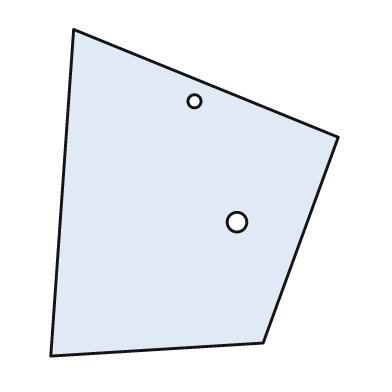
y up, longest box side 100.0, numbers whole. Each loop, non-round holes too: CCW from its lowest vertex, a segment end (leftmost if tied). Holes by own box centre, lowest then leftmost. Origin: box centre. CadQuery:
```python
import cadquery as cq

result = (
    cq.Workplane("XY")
    .moveTo(-44.0, -50.0)
    .lineTo(21.0, -46.0)
    .lineTo(44.0, 17.0)
    .lineTo(-37.0, 50.0)
    .close()
    .moveTo(13.0, -9.0)
    .circle(3.0)
    .moveTo(0.0, 28.0)
    .circle(2.0)
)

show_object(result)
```